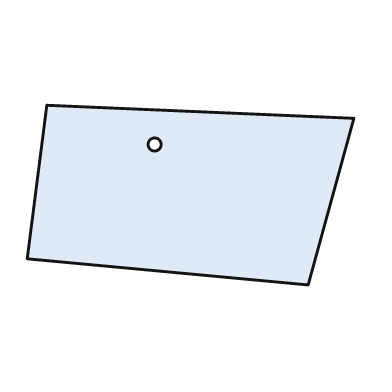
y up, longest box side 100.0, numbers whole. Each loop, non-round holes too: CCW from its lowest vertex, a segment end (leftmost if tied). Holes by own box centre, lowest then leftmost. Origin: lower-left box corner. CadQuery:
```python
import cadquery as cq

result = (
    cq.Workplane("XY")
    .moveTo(86.0, 0.0)
    .lineTo(100.0, 51.0)
    .lineTo(6.0, 55.0)
    .lineTo(0.0, 8.0)
    .close()
    .moveTo(39.0, 43.0)
    .circle(2.0)
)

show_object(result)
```